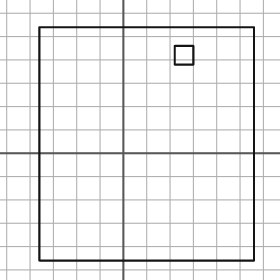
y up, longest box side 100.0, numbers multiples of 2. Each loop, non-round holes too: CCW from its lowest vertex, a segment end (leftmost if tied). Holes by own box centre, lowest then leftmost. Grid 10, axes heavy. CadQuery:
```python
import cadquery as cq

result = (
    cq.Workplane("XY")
    .moveTo(-36.0, -46.0)
    .lineTo(56.0, -46.0)
    .lineTo(56.0, 54.0)
    .lineTo(-36.0, 54.0)
    .close()
    .moveTo(22.0, 38.0)
    .lineTo(30.0, 38.0)
    .lineTo(30.0, 46.0)
    .lineTo(22.0, 46.0)
    .close()
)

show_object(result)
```